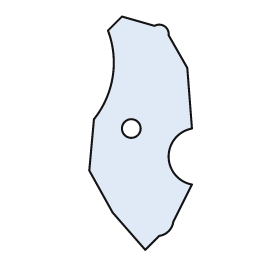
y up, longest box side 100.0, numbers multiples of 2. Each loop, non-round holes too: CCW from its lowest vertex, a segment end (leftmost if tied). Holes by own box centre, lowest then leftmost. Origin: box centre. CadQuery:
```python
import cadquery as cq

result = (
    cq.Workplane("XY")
    .moveTo(2.0, -50.0)
    .lineTo(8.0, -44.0)
    .threePointArc((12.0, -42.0), (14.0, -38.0))
    .lineTo(22.0, -22.0)
    .threePointArc((12.0, -10.0), (22.0, 2.0))
    .lineTo(20.0, 28.0)
    .lineTo(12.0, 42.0)
    .threePointArc((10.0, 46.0), (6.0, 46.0))
    .lineTo(-8.0, 50.0)
    .lineTo(-14.0, 44.0)
    .threePointArc((-12.0, 24.0), (-20.0, 6.0))
    .lineTo(-22.0, -16.0)
    .lineTo(-12.0, -34.0)
    .close()
    .moveTo(-4.0, 2.0)
    .circle(4.0)
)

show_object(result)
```